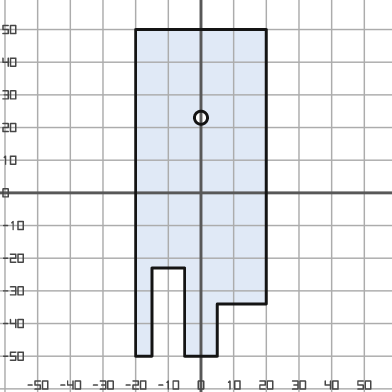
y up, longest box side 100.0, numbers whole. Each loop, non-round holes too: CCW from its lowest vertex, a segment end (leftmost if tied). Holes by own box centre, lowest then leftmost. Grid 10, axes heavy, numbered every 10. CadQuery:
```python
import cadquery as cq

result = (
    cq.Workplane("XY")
    .moveTo(-20.0, -50.0)
    .lineTo(-15.0, -50.0)
    .lineTo(-15.0, -23.0)
    .lineTo(-5.0, -23.0)
    .lineTo(-5.0, -50.0)
    .lineTo(5.0, -50.0)
    .lineTo(5.0, -34.0)
    .lineTo(20.0, -34.0)
    .lineTo(20.0, 50.0)
    .lineTo(-20.0, 50.0)
    .close()
    .moveTo(0.0, 23.0)
    .circle(2.0)
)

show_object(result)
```